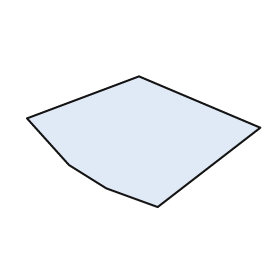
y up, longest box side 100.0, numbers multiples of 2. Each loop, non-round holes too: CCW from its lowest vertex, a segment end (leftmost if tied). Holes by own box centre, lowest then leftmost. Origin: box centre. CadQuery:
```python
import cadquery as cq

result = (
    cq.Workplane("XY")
    .moveTo(6.0, -28.0)
    .lineTo(50.0, 6.0)
    .lineTo(-2.0, 28.0)
    .lineTo(-50.0, 10.0)
    .lineTo(-32.0, -10.0)
    .lineTo(-16.0, -20.0)
    .close()
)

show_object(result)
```